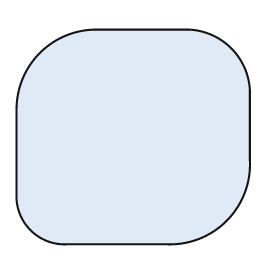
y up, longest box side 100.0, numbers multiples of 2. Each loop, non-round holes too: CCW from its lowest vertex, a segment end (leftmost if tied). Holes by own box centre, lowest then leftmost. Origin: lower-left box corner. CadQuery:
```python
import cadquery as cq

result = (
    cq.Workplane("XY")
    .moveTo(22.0, 0.0)
    .lineTo(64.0, 0.0)
    .threePointArc((90.0, 10.0), (100.0, 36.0))
    .lineTo(100.0, 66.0)
    .threePointArc((92.0, 84.0), (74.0, 92.0))
    .lineTo(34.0, 92.0)
    .threePointArc((10.0, 82.0), (0.0, 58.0))
    .lineTo(0.0, 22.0)
    .threePointArc((6.0, 6.0), (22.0, 0.0))
    .close()
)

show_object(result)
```